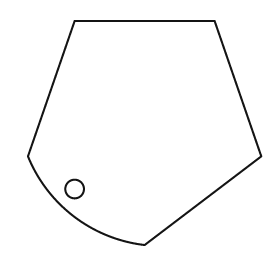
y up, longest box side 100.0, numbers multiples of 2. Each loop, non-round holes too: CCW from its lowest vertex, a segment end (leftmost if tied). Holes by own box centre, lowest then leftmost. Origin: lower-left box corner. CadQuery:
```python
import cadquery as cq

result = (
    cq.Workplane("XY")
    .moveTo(50.0, 0.0)
    .lineTo(100.0, 38.0)
    .lineTo(80.0, 96.0)
    .lineTo(20.0, 96.0)
    .lineTo(0.0, 38.0)
    .threePointArc((20.0, 12.0), (50.0, 0.0))
    .close()
    .moveTo(20.0, 24.0)
    .circle(4.0)
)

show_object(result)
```